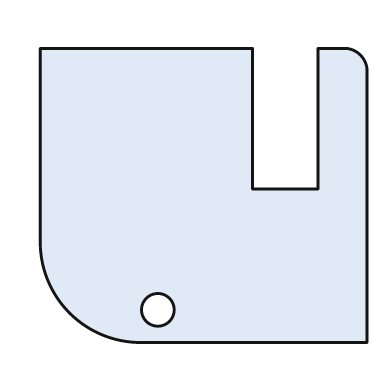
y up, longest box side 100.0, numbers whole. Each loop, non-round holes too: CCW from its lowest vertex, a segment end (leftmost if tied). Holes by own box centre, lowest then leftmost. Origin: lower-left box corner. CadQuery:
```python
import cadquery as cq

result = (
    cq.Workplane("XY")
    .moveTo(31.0, 0.0)
    .lineTo(100.0, 0.0)
    .lineTo(100.0, 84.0)
    .threePointArc((98.0, 88.0), (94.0, 90.0))
    .lineTo(85.0, 90.0)
    .lineTo(85.0, 47.0)
    .lineTo(65.0, 47.0)
    .lineTo(65.0, 90.0)
    .lineTo(0.0, 90.0)
    .lineTo(0.0, 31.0)
    .threePointArc((9.0, 9.0), (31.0, 0.0))
    .close()
    .moveTo(36.0, 10.0)
    .circle(5.0)
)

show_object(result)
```